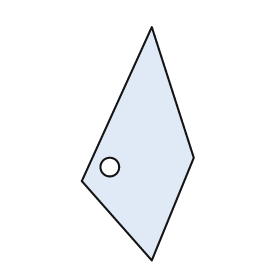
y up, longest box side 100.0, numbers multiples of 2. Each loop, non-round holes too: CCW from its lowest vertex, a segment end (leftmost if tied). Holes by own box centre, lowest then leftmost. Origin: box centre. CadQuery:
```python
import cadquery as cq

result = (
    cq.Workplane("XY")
    .moveTo(6.0, -50.0)
    .lineTo(24.0, -6.0)
    .lineTo(6.0, 50.0)
    .lineTo(-24.0, -16.0)
    .close()
    .moveTo(-12.0, -10.0)
    .circle(4.0)
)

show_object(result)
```